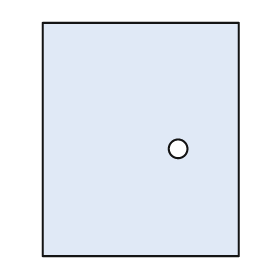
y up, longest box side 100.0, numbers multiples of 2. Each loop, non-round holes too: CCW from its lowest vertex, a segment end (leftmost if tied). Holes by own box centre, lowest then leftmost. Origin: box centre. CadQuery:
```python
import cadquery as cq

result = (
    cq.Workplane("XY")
    .moveTo(-42.0, -50.0)
    .lineTo(42.0, -50.0)
    .lineTo(42.0, 50.0)
    .lineTo(-42.0, 50.0)
    .close()
    .moveTo(16.0, -4.0)
    .circle(4.0)
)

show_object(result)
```